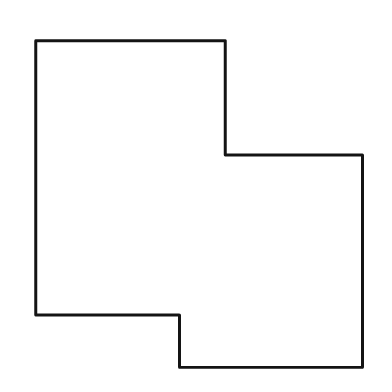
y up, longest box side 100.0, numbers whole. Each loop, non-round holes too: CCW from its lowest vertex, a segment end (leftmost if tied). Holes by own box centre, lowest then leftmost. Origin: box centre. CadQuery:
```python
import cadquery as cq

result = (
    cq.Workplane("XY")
    .moveTo(-6.0, -50.0)
    .lineTo(50.0, -50.0)
    .lineTo(50.0, 15.0)
    .lineTo(8.0, 15.0)
    .lineTo(8.0, 50.0)
    .lineTo(-50.0, 50.0)
    .lineTo(-50.0, -34.0)
    .lineTo(-6.0, -34.0)
    .close()
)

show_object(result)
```